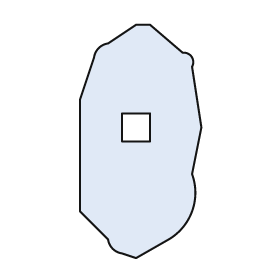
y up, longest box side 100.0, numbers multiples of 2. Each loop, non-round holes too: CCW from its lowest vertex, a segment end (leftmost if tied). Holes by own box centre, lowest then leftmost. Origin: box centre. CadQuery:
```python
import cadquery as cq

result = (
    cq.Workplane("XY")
    .moveTo(-2.0, -50.0)
    .lineTo(12.0, -42.0)
    .threePointArc((22.0, -30.0), (22.0, -14.0))
    .lineTo(26.0, 6.0)
    .lineTo(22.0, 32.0)
    .threePointArc((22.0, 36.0), (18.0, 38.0))
    .lineTo(4.0, 50.0)
    .lineTo(-2.0, 50.0)
    .lineTo(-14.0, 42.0)
    .threePointArc((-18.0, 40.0), (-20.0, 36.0))
    .lineTo(-26.0, 18.0)
    .lineTo(-26.0, -30.0)
    .lineTo(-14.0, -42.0)
    .threePointArc((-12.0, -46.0), (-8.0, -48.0))
    .close()
    .moveTo(-8.0, 0.0)
    .lineTo(4.0, 0.0)
    .lineTo(4.0, 12.0)
    .lineTo(-8.0, 12.0)
    .close()
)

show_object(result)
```